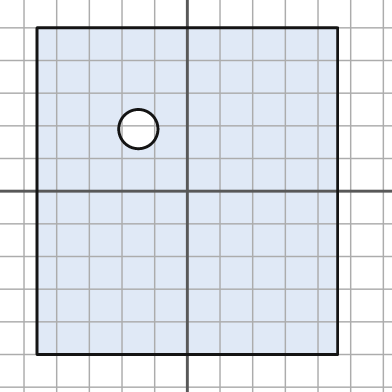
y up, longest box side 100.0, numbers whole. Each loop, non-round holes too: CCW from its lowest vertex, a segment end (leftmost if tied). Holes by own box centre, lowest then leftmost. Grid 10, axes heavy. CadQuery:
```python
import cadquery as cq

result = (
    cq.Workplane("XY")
    .moveTo(-46.0, -50.0)
    .lineTo(46.0, -50.0)
    .lineTo(46.0, 50.0)
    .lineTo(-46.0, 50.0)
    .close()
    .moveTo(-15.0, 19.0)
    .circle(6.0)
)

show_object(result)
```